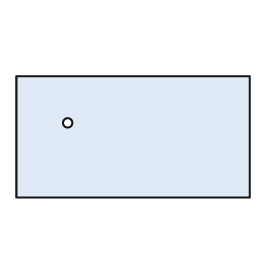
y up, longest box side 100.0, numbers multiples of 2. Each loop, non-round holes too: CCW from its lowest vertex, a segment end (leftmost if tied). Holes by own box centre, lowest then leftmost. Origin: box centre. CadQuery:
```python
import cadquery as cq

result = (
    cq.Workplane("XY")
    .moveTo(-50.0, -26.0)
    .lineTo(50.0, -26.0)
    .lineTo(50.0, 26.0)
    .lineTo(-50.0, 26.0)
    .close()
    .moveTo(-28.0, 6.0)
    .circle(2.0)
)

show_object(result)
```